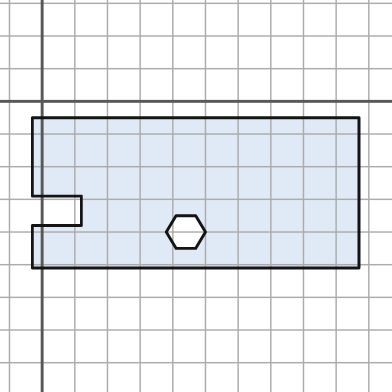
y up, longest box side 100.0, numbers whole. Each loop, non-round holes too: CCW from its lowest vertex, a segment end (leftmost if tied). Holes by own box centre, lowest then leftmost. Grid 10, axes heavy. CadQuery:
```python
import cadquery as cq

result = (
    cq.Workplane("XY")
    .moveTo(-3.0, -51.0)
    .lineTo(97.0, -51.0)
    .lineTo(97.0, -5.0)
    .lineTo(-3.0, -5.0)
    .lineTo(-3.0, -29.0)
    .lineTo(12.0, -29.0)
    .lineTo(12.0, -38.0)
    .lineTo(-3.0, -38.0)
    .close()
    .moveTo(41.0, -45.0)
    .lineTo(47.0, -45.0)
    .lineTo(50.0, -40.0)
    .lineTo(47.0, -35.0)
    .lineTo(41.0, -35.0)
    .lineTo(38.0, -40.0)
    .close()
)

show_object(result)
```